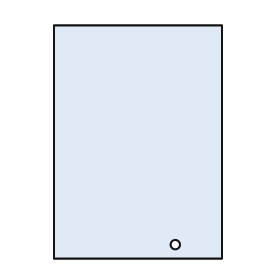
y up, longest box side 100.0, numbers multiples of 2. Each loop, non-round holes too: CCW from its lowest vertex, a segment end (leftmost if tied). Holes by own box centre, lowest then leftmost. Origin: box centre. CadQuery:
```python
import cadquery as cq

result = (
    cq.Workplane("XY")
    .moveTo(-36.0, -50.0)
    .lineTo(36.0, -50.0)
    .lineTo(36.0, 50.0)
    .lineTo(-36.0, 50.0)
    .close()
    .moveTo(16.0, -44.0)
    .circle(2.0)
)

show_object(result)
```